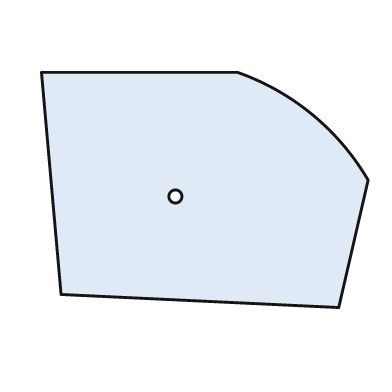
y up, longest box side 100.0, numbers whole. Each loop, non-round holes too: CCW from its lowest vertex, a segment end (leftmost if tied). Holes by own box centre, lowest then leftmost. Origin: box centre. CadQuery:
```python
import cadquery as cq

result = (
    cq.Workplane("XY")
    .moveTo(41.0, -36.0)
    .lineTo(50.0, 3.0)
    .threePointArc((33.0, 23.0), (10.0, 36.0))
    .lineTo(-50.0, 36.0)
    .lineTo(-44.0, -32.0)
    .close()
    .moveTo(-9.0, -2.0)
    .circle(2.0)
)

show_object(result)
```